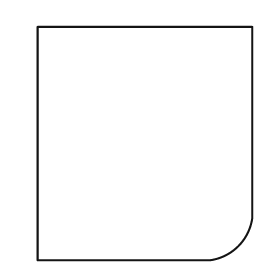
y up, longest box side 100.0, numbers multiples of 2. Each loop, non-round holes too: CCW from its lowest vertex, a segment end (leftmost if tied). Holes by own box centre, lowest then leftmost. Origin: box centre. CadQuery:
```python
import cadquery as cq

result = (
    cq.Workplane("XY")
    .moveTo(-46.0, -50.0)
    .lineTo(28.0, -50.0)
    .threePointArc((40.0, -44.0), (46.0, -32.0))
    .lineTo(46.0, 50.0)
    .lineTo(-46.0, 50.0)
    .close()
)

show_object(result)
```